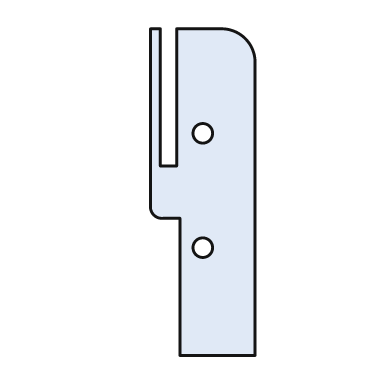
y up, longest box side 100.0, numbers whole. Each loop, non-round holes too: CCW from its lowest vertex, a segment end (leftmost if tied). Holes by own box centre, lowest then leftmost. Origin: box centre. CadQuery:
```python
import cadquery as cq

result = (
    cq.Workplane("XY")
    .moveTo(-7.0, -50.0)
    .lineTo(16.0, -50.0)
    .lineTo(16.0, 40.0)
    .threePointArc((13.0, 47.0), (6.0, 50.0))
    .lineTo(-8.0, 50.0)
    .lineTo(-8.0, 8.0)
    .lineTo(-13.0, 8.0)
    .lineTo(-13.0, 50.0)
    .lineTo(-16.0, 50.0)
    .lineTo(-16.0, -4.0)
    .threePointArc((-15.0, -7.0), (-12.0, -8.0))
    .lineTo(-7.0, -8.0)
    .close()
    .moveTo(0.0, -17.0)
    .circle(3.0)
    .moveTo(0.0, 18.0)
    .circle(3.0)
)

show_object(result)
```